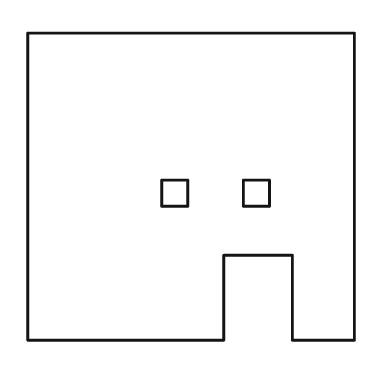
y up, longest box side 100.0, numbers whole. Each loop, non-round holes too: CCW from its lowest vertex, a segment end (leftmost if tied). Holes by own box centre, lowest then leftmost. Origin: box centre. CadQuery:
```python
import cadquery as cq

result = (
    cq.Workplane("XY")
    .moveTo(-50.0, -47.0)
    .lineTo(10.0, -47.0)
    .lineTo(10.0, -21.0)
    .lineTo(31.0, -21.0)
    .lineTo(31.0, -47.0)
    .lineTo(50.0, -47.0)
    .lineTo(50.0, 47.0)
    .lineTo(-50.0, 47.0)
    .close()
    .moveTo(-9.0, -6.0)
    .lineTo(-1.0, -6.0)
    .lineTo(-1.0, 2.0)
    .lineTo(-9.0, 2.0)
    .close()
    .moveTo(16.0, -6.0)
    .lineTo(24.0, -6.0)
    .lineTo(24.0, 2.0)
    .lineTo(16.0, 2.0)
    .close()
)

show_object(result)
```